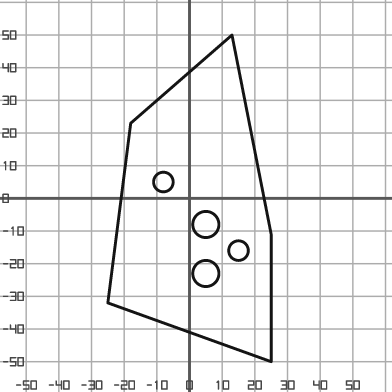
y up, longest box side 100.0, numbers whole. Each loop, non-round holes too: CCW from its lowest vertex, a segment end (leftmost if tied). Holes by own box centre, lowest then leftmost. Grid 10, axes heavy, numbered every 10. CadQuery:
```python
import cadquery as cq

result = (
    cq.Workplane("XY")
    .moveTo(25.0, -50.0)
    .lineTo(25.0, -11.0)
    .lineTo(13.0, 50.0)
    .lineTo(-18.0, 23.0)
    .lineTo(-25.0, -32.0)
    .close()
    .moveTo(5.0, -23.0)
    .circle(4.0)
    .moveTo(15.0, -16.0)
    .circle(3.0)
    .moveTo(5.0, -8.0)
    .circle(4.0)
    .moveTo(-8.0, 5.0)
    .circle(3.0)
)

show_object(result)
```